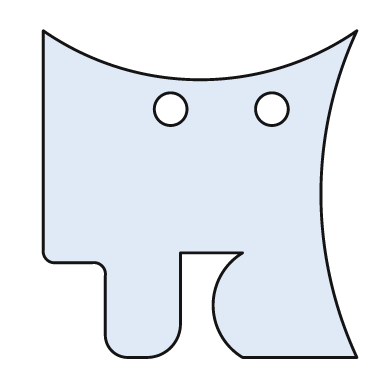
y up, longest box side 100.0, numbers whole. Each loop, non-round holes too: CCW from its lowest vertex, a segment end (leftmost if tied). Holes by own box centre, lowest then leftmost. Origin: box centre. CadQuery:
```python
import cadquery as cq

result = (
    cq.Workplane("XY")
    .moveTo(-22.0, -50.0)
    .lineTo(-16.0, -50.0)
    .threePointArc((-9.0, -47.0), (-6.0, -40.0))
    .lineTo(-6.0, -18.0)
    .lineTo(13.0, -18.0)
    .threePointArc((4.0, -34.0), (13.0, -50.0))
    .lineTo(48.0, -50.0)
    .threePointArc((37.0, 0.0), (48.0, 50.0))
    .threePointArc((0.0, 35.0), (-48.0, 50.0))
    .lineTo(-48.0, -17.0)
    .threePointArc((-47.0, -20.0), (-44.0, -21.0))
    .lineTo(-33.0, -21.0)
    .threePointArc((-30.0, -22.0), (-29.0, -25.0))
    .lineTo(-29.0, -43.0)
    .threePointArc((-27.0, -48.0), (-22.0, -50.0))
    .close()
    .moveTo(-9.0, 26.0)
    .circle(5.0)
    .moveTo(22.0, 26.0)
    .circle(5.0)
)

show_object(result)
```